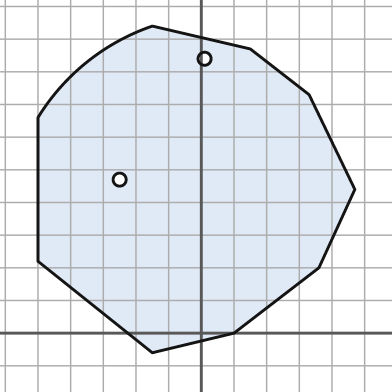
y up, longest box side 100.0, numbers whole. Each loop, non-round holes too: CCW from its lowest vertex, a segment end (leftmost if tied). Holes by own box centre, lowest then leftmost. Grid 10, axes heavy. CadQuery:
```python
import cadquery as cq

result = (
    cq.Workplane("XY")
    .moveTo(-15.0, -6.0)
    .lineTo(10.0, 0.0)
    .lineTo(36.0, 20.0)
    .lineTo(47.0, 44.0)
    .lineTo(33.0, 73.0)
    .lineTo(15.0, 87.0)
    .lineTo(-15.0, 94.0)
    .threePointArc((-35.0, 83.0), (-50.0, 66.0))
    .lineTo(-50.0, 22.0)
    .close()
    .moveTo(-25.0, 47.0)
    .circle(2.0)
    .moveTo(1.0, 84.0)
    .circle(2.0)
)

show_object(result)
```